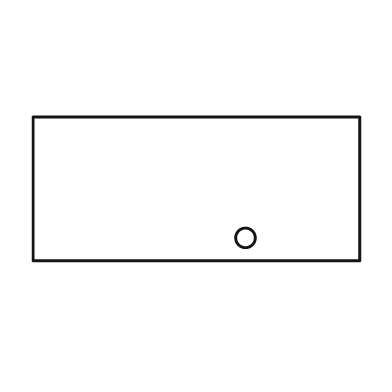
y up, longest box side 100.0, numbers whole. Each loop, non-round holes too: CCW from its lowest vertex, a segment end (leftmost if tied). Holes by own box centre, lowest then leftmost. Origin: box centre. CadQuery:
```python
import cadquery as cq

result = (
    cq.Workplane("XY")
    .moveTo(-50.0, -22.0)
    .lineTo(50.0, -22.0)
    .lineTo(50.0, 22.0)
    .lineTo(-50.0, 22.0)
    .close()
    .moveTo(15.0, -15.0)
    .circle(3.0)
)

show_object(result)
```